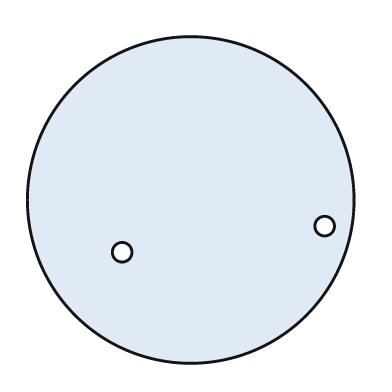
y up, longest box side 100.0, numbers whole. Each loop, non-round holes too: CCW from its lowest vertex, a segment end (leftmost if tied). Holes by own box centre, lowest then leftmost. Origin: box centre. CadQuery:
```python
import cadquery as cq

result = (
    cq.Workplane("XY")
    .moveTo(0.0, 0.0)
    .circle(50.0)
    .moveTo(-21.0, -16.0)
    .circle(3.0)
    .moveTo(41.0, -8.0)
    .circle(3.0)
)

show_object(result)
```